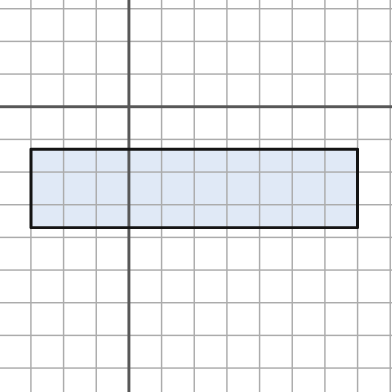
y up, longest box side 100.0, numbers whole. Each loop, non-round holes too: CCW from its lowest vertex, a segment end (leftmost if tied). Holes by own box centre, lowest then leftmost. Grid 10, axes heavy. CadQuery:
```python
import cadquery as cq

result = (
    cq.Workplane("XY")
    .moveTo(-30.0, -37.0)
    .lineTo(70.0, -37.0)
    .lineTo(70.0, -13.0)
    .lineTo(-30.0, -13.0)
    .close()
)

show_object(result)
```